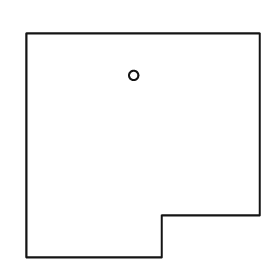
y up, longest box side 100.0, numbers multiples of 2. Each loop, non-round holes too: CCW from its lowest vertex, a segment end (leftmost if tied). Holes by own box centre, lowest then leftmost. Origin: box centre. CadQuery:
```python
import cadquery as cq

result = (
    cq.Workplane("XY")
    .moveTo(-50.0, -48.0)
    .lineTo(8.0, -48.0)
    .lineTo(8.0, -30.0)
    .lineTo(50.0, -30.0)
    .lineTo(50.0, 48.0)
    .lineTo(-50.0, 48.0)
    .close()
    .moveTo(-4.0, 30.0)
    .circle(2.0)
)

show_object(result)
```